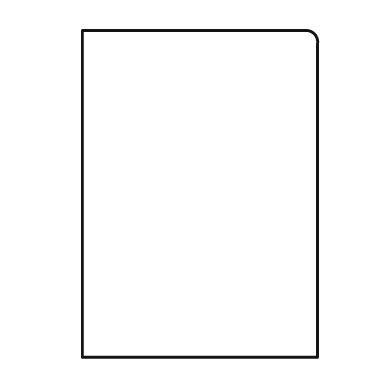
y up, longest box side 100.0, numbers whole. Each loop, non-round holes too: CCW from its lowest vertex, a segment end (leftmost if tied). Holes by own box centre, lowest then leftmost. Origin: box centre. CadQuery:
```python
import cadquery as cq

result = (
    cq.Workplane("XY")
    .moveTo(-36.0, -50.0)
    .lineTo(36.0, -50.0)
    .lineTo(36.0, 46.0)
    .threePointArc((35.0, 49.0), (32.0, 50.0))
    .lineTo(-36.0, 50.0)
    .close()
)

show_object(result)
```